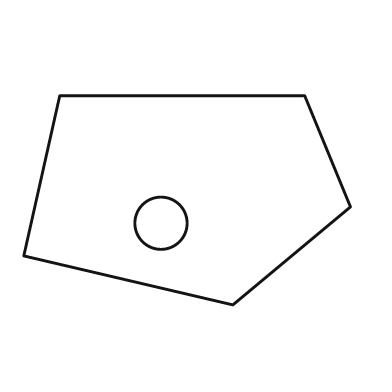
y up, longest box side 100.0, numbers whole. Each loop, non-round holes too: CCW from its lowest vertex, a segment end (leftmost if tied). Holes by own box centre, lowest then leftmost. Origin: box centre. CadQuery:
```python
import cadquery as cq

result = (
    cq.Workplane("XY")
    .moveTo(14.0, -32.0)
    .lineTo(50.0, -2.0)
    .lineTo(36.0, 32.0)
    .lineTo(-39.0, 32.0)
    .lineTo(-50.0, -17.0)
    .close()
    .moveTo(-8.0, -7.0)
    .circle(8.0)
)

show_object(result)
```